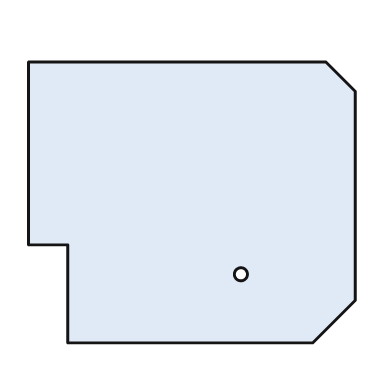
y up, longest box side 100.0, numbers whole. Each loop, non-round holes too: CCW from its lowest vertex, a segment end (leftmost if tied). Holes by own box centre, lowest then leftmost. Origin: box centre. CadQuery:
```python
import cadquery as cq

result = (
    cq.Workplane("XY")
    .moveTo(-38.0, -43.0)
    .lineTo(37.0, -43.0)
    .lineTo(50.0, -30.0)
    .lineTo(50.0, 34.0)
    .lineTo(41.0, 43.0)
    .lineTo(-50.0, 43.0)
    .lineTo(-50.0, -13.0)
    .lineTo(-38.0, -13.0)
    .close()
    .moveTo(15.0, -22.0)
    .circle(2.0)
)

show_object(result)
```